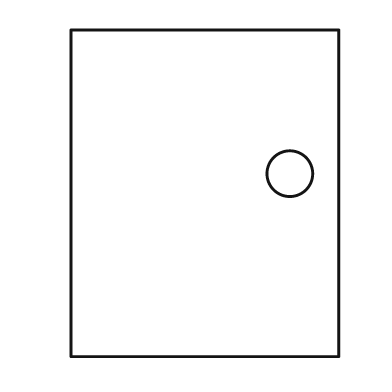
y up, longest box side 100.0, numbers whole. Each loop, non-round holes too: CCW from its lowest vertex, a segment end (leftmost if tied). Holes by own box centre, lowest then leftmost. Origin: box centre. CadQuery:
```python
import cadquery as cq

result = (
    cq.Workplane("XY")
    .moveTo(-41.0, -50.0)
    .lineTo(41.0, -50.0)
    .lineTo(41.0, 50.0)
    .lineTo(-41.0, 50.0)
    .close()
    .moveTo(26.0, 6.0)
    .circle(7.0)
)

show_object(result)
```